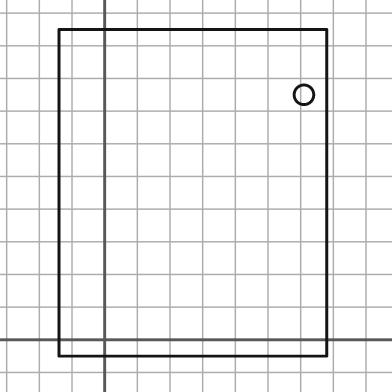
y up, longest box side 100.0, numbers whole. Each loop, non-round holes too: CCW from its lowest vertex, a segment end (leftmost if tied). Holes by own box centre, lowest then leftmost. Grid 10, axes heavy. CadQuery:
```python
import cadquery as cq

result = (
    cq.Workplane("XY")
    .moveTo(-14.0, -5.0)
    .lineTo(68.0, -5.0)
    .lineTo(68.0, 95.0)
    .lineTo(-14.0, 95.0)
    .close()
    .moveTo(61.0, 75.0)
    .circle(3.0)
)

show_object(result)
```